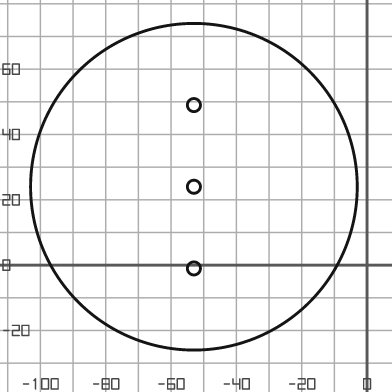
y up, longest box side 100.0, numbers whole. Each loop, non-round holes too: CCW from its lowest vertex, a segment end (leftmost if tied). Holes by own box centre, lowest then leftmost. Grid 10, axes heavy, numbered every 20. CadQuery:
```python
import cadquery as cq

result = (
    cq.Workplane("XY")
    .moveTo(-53.0, 24.0)
    .circle(50.0)
    .moveTo(-53.0, -1.0)
    .circle(2.0)
    .moveTo(-53.0, 24.0)
    .circle(2.0)
    .moveTo(-53.0, 49.0)
    .circle(2.0)
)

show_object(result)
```